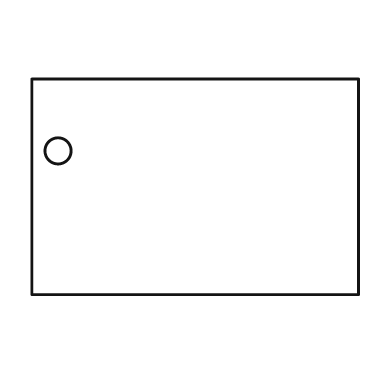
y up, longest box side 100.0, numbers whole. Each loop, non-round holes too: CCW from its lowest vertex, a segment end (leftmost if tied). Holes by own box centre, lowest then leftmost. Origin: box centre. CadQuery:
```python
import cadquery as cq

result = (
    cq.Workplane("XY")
    .moveTo(-50.0, -33.0)
    .lineTo(50.0, -33.0)
    .lineTo(50.0, 33.0)
    .lineTo(-50.0, 33.0)
    .close()
    .moveTo(-42.0, 11.0)
    .circle(4.0)
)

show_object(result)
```